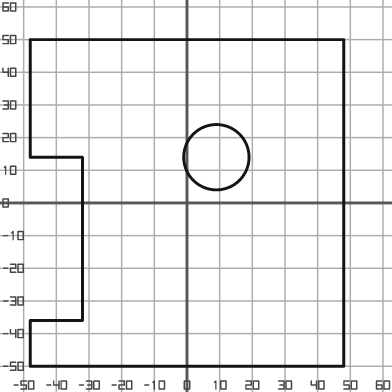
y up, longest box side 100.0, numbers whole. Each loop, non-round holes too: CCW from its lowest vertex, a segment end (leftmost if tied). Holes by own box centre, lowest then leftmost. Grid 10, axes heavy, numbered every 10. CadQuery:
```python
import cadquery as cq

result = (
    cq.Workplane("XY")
    .moveTo(-48.0, -50.0)
    .lineTo(48.0, -50.0)
    .lineTo(48.0, 50.0)
    .lineTo(-48.0, 50.0)
    .lineTo(-48.0, 14.0)
    .lineTo(-32.0, 14.0)
    .lineTo(-32.0, -36.0)
    .lineTo(-48.0, -36.0)
    .close()
    .moveTo(9.0, 14.0)
    .circle(10.0)
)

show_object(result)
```